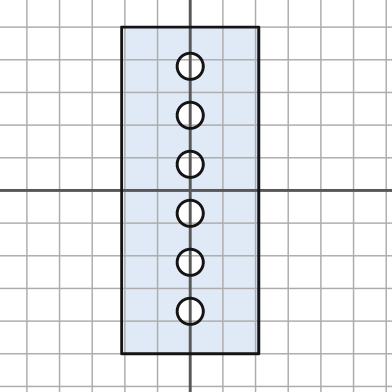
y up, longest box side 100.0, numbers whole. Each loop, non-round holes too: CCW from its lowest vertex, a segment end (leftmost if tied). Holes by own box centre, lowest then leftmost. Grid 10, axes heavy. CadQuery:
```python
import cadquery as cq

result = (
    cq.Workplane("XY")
    .moveTo(-21.0, -50.0)
    .lineTo(21.0, -50.0)
    .lineTo(21.0, 50.0)
    .lineTo(-21.0, 50.0)
    .close()
    .moveTo(0.0, -37.0)
    .circle(4.0)
    .moveTo(0.0, -22.0)
    .circle(4.0)
    .moveTo(0.0, -7.0)
    .circle(4.0)
    .moveTo(0.0, 8.0)
    .circle(4.0)
    .moveTo(0.0, 23.0)
    .circle(4.0)
    .moveTo(0.0, 38.0)
    .circle(4.0)
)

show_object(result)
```